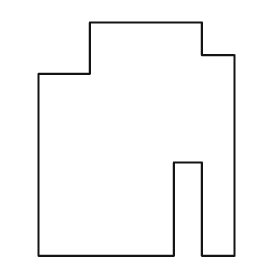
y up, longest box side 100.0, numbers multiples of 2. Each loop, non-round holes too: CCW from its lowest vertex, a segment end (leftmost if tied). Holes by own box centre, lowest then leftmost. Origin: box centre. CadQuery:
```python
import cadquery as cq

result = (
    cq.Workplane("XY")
    .moveTo(-42.0, -50.0)
    .lineTo(16.0, -50.0)
    .lineTo(16.0, -10.0)
    .lineTo(28.0, -10.0)
    .lineTo(28.0, -50.0)
    .lineTo(42.0, -50.0)
    .lineTo(42.0, 36.0)
    .lineTo(28.0, 36.0)
    .lineTo(28.0, 50.0)
    .lineTo(-20.0, 50.0)
    .lineTo(-20.0, 28.0)
    .lineTo(-42.0, 28.0)
    .close()
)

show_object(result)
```